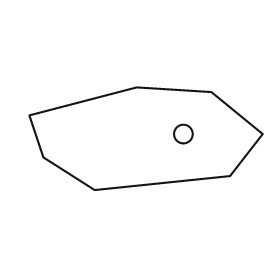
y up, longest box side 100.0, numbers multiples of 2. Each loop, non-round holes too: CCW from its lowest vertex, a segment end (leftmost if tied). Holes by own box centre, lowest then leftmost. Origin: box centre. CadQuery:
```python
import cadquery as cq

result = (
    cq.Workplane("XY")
    .moveTo(-22.0, -22.0)
    .lineTo(36.0, -16.0)
    .lineTo(50.0, 2.0)
    .lineTo(28.0, 20.0)
    .lineTo(-4.0, 22.0)
    .lineTo(-50.0, 10.0)
    .lineTo(-44.0, -8.0)
    .close()
    .moveTo(16.0, 2.0)
    .circle(4.0)
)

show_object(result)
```